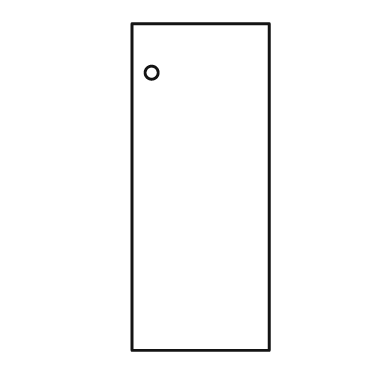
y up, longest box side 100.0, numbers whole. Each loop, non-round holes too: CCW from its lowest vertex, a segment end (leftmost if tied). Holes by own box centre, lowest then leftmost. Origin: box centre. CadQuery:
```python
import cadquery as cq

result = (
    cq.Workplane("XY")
    .moveTo(-21.0, -50.0)
    .lineTo(21.0, -50.0)
    .lineTo(21.0, 50.0)
    .lineTo(-21.0, 50.0)
    .close()
    .moveTo(-15.0, 35.0)
    .circle(2.0)
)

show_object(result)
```